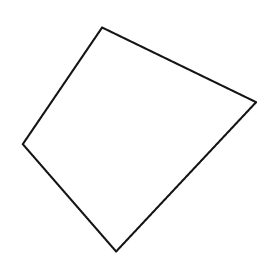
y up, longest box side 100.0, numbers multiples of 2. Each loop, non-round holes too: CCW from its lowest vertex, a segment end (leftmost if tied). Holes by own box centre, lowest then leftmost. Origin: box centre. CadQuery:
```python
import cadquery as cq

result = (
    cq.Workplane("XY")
    .moveTo(-10.0, -48.0)
    .lineTo(50.0, 16.0)
    .lineTo(-16.0, 48.0)
    .lineTo(-50.0, -2.0)
    .close()
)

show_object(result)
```